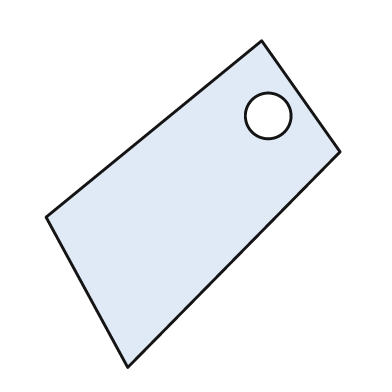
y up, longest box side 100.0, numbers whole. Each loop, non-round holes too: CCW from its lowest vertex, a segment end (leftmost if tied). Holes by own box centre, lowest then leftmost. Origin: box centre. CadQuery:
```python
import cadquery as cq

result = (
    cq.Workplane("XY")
    .moveTo(-20.0, -50.0)
    .lineTo(45.0, 16.0)
    .lineTo(21.0, 50.0)
    .lineTo(-45.0, -4.0)
    .close()
    .moveTo(23.0, 27.0)
    .circle(7.0)
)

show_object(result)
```